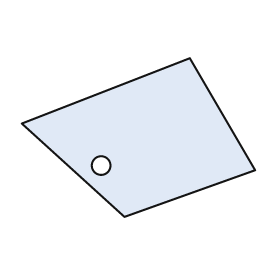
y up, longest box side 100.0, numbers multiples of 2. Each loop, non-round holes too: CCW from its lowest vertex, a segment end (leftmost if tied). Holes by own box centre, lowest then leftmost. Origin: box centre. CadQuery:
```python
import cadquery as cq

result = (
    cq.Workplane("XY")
    .moveTo(-6.0, -34.0)
    .lineTo(50.0, -14.0)
    .lineTo(22.0, 34.0)
    .lineTo(-50.0, 6.0)
    .close()
    .moveTo(-16.0, -12.0)
    .circle(4.0)
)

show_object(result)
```